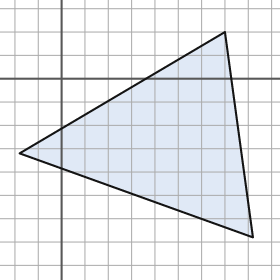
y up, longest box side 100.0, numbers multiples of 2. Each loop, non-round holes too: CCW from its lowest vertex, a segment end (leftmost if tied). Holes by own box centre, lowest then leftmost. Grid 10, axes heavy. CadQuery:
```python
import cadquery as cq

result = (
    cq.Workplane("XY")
    .moveTo(82.0, -68.0)
    .lineTo(70.0, 20.0)
    .lineTo(-18.0, -32.0)
    .close()
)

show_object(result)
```